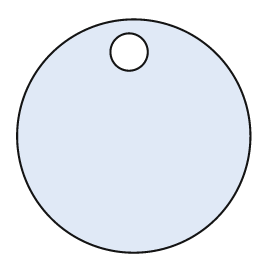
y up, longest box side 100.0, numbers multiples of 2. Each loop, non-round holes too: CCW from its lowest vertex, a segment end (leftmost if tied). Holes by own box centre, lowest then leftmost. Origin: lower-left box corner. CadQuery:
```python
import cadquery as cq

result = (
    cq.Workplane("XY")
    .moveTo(50.0, 50.0)
    .circle(50.0)
    .moveTo(48.0, 86.0)
    .circle(8.0)
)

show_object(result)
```